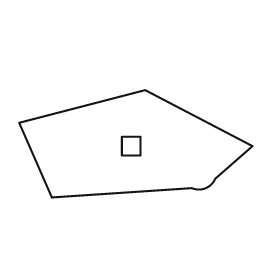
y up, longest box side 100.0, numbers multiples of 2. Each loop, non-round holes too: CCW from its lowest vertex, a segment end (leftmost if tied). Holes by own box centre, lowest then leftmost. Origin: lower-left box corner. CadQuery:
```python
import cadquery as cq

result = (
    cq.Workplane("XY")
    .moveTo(14.0, 0.0)
    .lineTo(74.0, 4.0)
    .threePointArc((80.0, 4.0), (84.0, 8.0))
    .lineTo(100.0, 22.0)
    .lineTo(54.0, 46.0)
    .lineTo(0.0, 32.0)
    .close()
    .moveTo(44.0, 18.0)
    .lineTo(52.0, 18.0)
    .lineTo(52.0, 26.0)
    .lineTo(44.0, 26.0)
    .close()
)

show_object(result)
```